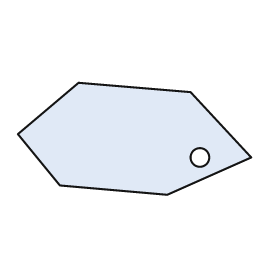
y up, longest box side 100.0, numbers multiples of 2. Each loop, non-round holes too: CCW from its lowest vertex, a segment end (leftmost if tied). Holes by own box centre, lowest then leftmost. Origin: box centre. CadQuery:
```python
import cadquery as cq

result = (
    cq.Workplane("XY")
    .moveTo(14.0, -24.0)
    .lineTo(50.0, -8.0)
    .lineTo(24.0, 20.0)
    .lineTo(-24.0, 24.0)
    .lineTo(-50.0, 2.0)
    .lineTo(-32.0, -20.0)
    .close()
    .moveTo(28.0, -8.0)
    .circle(4.0)
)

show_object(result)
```